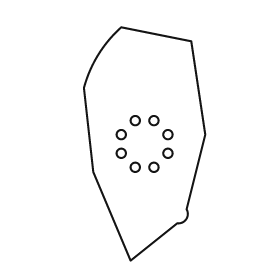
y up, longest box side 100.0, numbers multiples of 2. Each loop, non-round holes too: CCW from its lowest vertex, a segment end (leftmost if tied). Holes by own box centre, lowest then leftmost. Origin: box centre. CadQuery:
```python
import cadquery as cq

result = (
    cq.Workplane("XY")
    .moveTo(-6.0, -50.0)
    .lineTo(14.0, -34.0)
    .threePointArc((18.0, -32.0), (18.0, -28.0))
    .lineTo(26.0, 4.0)
    .lineTo(20.0, 44.0)
    .lineTo(-10.0, 50.0)
    .threePointArc((-20.0, 38.0), (-26.0, 24.0))
    .lineTo(-22.0, -12.0)
    .close()
    .moveTo(-4.0, -10.0)
    .circle(2.0)
    .moveTo(4.0, -10.0)
    .circle(2.0)
    .moveTo(-10.0, -4.0)
    .circle(2.0)
    .moveTo(10.0, -4.0)
    .circle(2.0)
    .moveTo(-10.0, 4.0)
    .circle(2.0)
    .moveTo(10.0, 4.0)
    .circle(2.0)
    .moveTo(-4.0, 10.0)
    .circle(2.0)
    .moveTo(4.0, 10.0)
    .circle(2.0)
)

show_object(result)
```